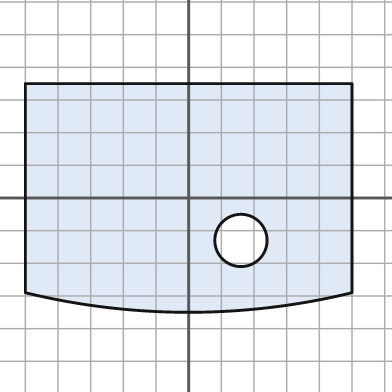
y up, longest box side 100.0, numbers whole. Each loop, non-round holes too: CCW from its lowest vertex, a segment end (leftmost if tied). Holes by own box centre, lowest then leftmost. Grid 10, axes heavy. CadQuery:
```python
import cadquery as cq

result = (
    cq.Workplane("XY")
    .moveTo(-50.0, -29.0)
    .threePointArc((0.0, -35.0), (50.0, -29.0))
    .lineTo(50.0, 35.0)
    .lineTo(-50.0, 35.0)
    .close()
    .moveTo(16.0, -13.0)
    .circle(8.0)
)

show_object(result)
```